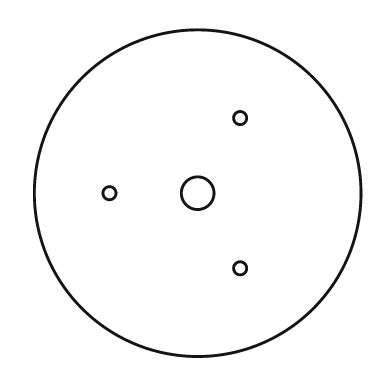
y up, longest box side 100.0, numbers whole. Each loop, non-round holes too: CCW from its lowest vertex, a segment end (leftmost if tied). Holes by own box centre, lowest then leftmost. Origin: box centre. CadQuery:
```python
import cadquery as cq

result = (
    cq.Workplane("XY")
    .moveTo(0.0, 0.0)
    .circle(50.0)
    .moveTo(13.0, -23.0)
    .circle(2.0)
    .moveTo(-27.0, 0.0)
    .circle(2.0)
    .moveTo(0.0, 0.0)
    .circle(5.0)
    .moveTo(13.0, 23.0)
    .circle(2.0)
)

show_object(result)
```